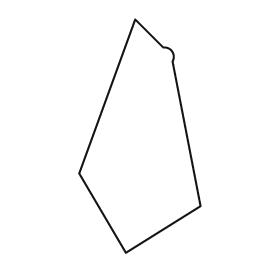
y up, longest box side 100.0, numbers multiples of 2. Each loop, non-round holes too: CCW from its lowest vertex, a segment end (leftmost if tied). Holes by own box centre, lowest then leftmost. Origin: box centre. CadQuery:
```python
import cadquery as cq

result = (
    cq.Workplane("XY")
    .moveTo(-6.0, -50.0)
    .lineTo(26.0, -30.0)
    .lineTo(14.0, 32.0)
    .threePointArc((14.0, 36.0), (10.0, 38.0))
    .lineTo(-2.0, 50.0)
    .lineTo(-26.0, -16.0)
    .close()
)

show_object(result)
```